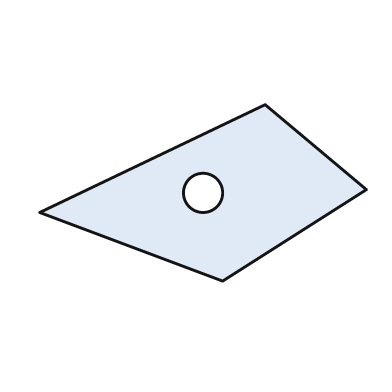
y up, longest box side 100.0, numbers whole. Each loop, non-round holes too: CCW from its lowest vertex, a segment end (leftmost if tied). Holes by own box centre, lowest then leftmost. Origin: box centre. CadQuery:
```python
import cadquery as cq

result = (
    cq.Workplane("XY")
    .moveTo(6.0, -27.0)
    .lineTo(50.0, 1.0)
    .lineTo(19.0, 27.0)
    .lineTo(-50.0, -6.0)
    .close()
    .moveTo(0.0, 0.0)
    .circle(6.0)
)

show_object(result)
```